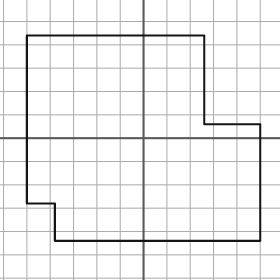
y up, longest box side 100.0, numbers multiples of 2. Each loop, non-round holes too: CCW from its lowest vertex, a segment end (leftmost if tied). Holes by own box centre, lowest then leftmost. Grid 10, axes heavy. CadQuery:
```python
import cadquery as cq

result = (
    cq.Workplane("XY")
    .moveTo(-38.0, -44.0)
    .lineTo(50.0, -44.0)
    .lineTo(50.0, 6.0)
    .lineTo(26.0, 6.0)
    .lineTo(26.0, 44.0)
    .lineTo(-50.0, 44.0)
    .lineTo(-50.0, -28.0)
    .lineTo(-38.0, -28.0)
    .close()
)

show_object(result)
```